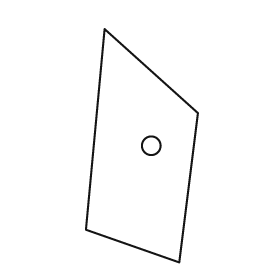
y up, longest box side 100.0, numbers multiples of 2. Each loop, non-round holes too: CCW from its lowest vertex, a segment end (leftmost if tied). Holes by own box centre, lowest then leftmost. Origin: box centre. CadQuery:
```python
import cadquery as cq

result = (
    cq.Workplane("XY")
    .moveTo(16.0, -50.0)
    .lineTo(24.0, 14.0)
    .lineTo(-16.0, 50.0)
    .lineTo(-24.0, -36.0)
    .close()
    .moveTo(4.0, 0.0)
    .circle(4.0)
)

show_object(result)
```